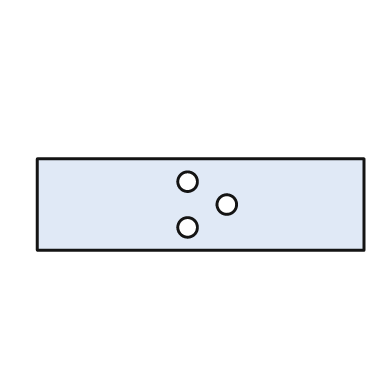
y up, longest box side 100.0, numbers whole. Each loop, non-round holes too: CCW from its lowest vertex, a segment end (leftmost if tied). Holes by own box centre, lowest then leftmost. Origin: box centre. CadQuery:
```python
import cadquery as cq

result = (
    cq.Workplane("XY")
    .moveTo(-50.0, -14.0)
    .lineTo(50.0, -14.0)
    .lineTo(50.0, 14.0)
    .lineTo(-50.0, 14.0)
    .close()
    .moveTo(-4.0, -7.0)
    .circle(3.0)
    .moveTo(8.0, 0.0)
    .circle(3.0)
    .moveTo(-4.0, 7.0)
    .circle(3.0)
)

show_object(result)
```